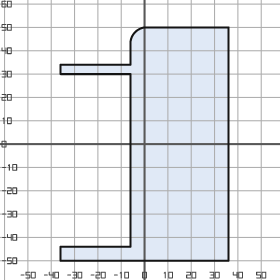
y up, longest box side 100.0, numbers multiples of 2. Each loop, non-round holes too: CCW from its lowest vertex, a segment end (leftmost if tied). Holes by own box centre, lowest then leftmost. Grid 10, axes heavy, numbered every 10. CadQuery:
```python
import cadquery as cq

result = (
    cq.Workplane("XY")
    .moveTo(-36.0, -50.0)
    .lineTo(36.0, -50.0)
    .lineTo(36.0, 50.0)
    .lineTo(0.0, 50.0)
    .threePointArc((-4.0, 48.0), (-6.0, 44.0))
    .lineTo(-6.0, 34.0)
    .lineTo(-36.0, 34.0)
    .lineTo(-36.0, 30.0)
    .lineTo(-6.0, 30.0)
    .lineTo(-6.0, -44.0)
    .lineTo(-36.0, -44.0)
    .close()
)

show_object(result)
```